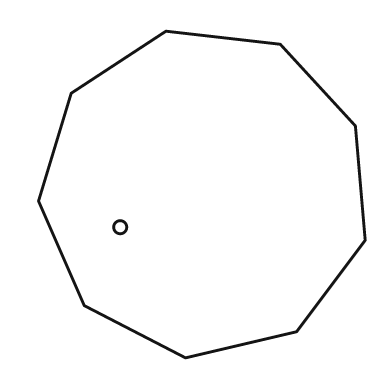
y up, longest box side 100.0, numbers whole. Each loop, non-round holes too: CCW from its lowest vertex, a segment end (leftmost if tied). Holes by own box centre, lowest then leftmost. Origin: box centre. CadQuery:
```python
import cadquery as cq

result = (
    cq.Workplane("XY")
    .moveTo(-5.0, -50.0)
    .lineTo(29.0, -42.0)
    .lineTo(50.0, -14.0)
    .lineTo(47.0, 21.0)
    .lineTo(24.0, 46.0)
    .lineTo(-11.0, 50.0)
    .lineTo(-40.0, 31.0)
    .lineTo(-50.0, -2.0)
    .lineTo(-36.0, -34.0)
    .close()
    .moveTo(-25.0, -10.0)
    .circle(2.0)
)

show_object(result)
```